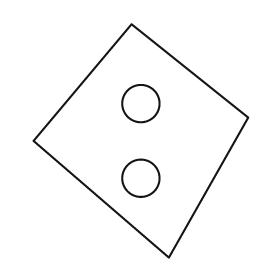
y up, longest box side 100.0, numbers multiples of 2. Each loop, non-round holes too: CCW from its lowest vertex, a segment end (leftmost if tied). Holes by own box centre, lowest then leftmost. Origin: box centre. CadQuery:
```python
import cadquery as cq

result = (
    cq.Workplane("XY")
    .moveTo(12.0, -50.0)
    .lineTo(46.0, 10.0)
    .lineTo(-4.0, 50.0)
    .lineTo(-46.0, 0.0)
    .close()
    .moveTo(0.0, -16.0)
    .circle(8.0)
    .moveTo(0.0, 16.0)
    .circle(8.0)
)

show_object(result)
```